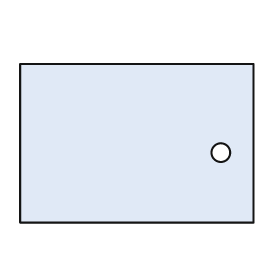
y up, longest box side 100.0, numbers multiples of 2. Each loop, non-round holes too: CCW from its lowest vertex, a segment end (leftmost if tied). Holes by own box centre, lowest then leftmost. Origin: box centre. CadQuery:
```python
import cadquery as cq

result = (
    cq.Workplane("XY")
    .moveTo(-50.0, -34.0)
    .lineTo(50.0, -34.0)
    .lineTo(50.0, 34.0)
    .lineTo(-50.0, 34.0)
    .close()
    .moveTo(36.0, -4.0)
    .circle(4.0)
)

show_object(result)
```